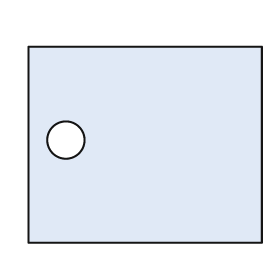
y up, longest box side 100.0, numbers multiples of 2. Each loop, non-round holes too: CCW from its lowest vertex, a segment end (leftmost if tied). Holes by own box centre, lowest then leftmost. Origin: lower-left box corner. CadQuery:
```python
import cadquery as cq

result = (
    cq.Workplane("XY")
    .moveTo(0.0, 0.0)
    .lineTo(100.0, 0.0)
    .lineTo(100.0, 84.0)
    .lineTo(0.0, 84.0)
    .close()
    .moveTo(16.0, 44.0)
    .circle(8.0)
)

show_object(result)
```